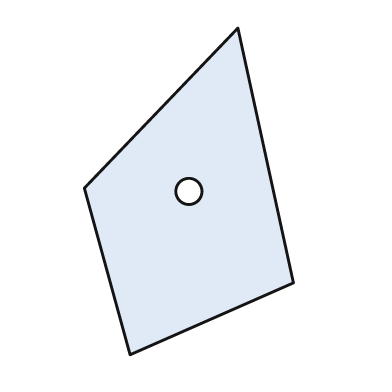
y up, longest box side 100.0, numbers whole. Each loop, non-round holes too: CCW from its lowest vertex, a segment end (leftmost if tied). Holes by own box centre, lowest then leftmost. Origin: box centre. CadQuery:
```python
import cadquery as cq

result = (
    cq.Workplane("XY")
    .moveTo(-18.0, -50.0)
    .lineTo(32.0, -28.0)
    .lineTo(15.0, 50.0)
    .lineTo(-32.0, 1.0)
    .close()
    .moveTo(0.0, 0.0)
    .circle(4.0)
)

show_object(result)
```